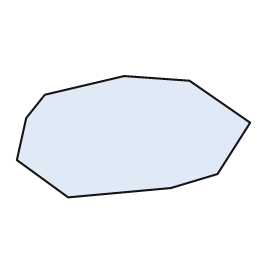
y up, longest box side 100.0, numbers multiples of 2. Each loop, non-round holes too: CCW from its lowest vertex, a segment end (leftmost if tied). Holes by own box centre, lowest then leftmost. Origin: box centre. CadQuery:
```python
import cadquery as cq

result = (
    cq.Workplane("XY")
    .moveTo(-28.0, -26.0)
    .lineTo(16.0, -22.0)
    .lineTo(36.0, -16.0)
    .lineTo(50.0, 6.0)
    .lineTo(24.0, 24.0)
    .lineTo(-4.0, 26.0)
    .lineTo(-38.0, 18.0)
    .lineTo(-46.0, 8.0)
    .lineTo(-50.0, -10.0)
    .close()
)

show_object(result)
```